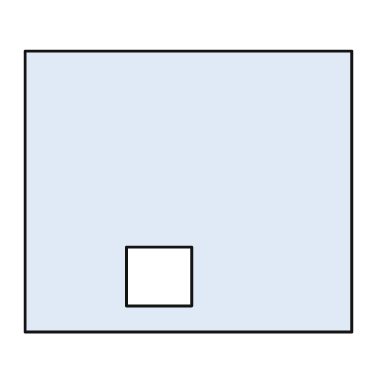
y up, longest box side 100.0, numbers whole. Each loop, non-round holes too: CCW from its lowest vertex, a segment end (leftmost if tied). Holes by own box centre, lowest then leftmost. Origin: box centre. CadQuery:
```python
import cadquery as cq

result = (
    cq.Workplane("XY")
    .moveTo(-50.0, -43.0)
    .lineTo(50.0, -43.0)
    .lineTo(50.0, 43.0)
    .lineTo(-50.0, 43.0)
    .close()
    .moveTo(-19.0, -35.0)
    .lineTo(1.0, -35.0)
    .lineTo(1.0, -17.0)
    .lineTo(-19.0, -17.0)
    .close()
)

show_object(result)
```